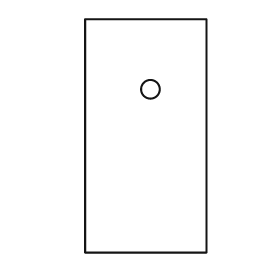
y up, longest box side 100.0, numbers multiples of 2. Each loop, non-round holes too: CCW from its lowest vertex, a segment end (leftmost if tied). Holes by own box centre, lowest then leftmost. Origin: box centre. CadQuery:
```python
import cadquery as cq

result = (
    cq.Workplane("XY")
    .moveTo(-26.0, -50.0)
    .lineTo(26.0, -50.0)
    .lineTo(26.0, 50.0)
    .lineTo(-26.0, 50.0)
    .close()
    .moveTo(2.0, 20.0)
    .circle(4.0)
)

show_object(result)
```